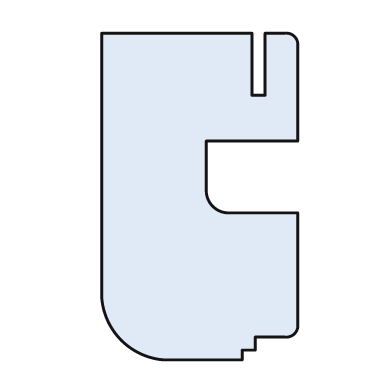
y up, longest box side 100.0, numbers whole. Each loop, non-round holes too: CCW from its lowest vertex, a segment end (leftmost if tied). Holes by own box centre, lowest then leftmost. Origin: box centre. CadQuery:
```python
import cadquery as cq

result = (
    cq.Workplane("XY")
    .moveTo(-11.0, -50.0)
    .lineTo(13.0, -50.0)
    .lineTo(13.0, -47.0)
    .lineTo(17.0, -47.0)
    .lineTo(17.0, -43.0)
    .lineTo(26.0, -43.0)
    .threePointArc((29.0, -42.0), (30.0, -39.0))
    .lineTo(30.0, -5.0)
    .lineTo(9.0, -5.0)
    .threePointArc((4.0, -3.0), (2.0, 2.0))
    .lineTo(2.0, 17.0)
    .lineTo(30.0, 17.0)
    .lineTo(30.0, 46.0)
    .threePointArc((29.0, 49.0), (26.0, 50.0))
    .lineTo(20.0, 50.0)
    .lineTo(20.0, 31.0)
    .lineTo(16.0, 31.0)
    .lineTo(16.0, 50.0)
    .lineTo(-30.0, 50.0)
    .lineTo(-30.0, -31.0)
    .threePointArc((-24.0, -44.0), (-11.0, -50.0))
    .close()
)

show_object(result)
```